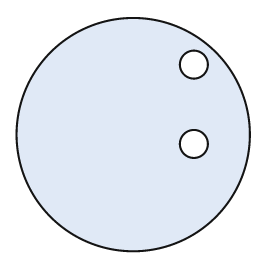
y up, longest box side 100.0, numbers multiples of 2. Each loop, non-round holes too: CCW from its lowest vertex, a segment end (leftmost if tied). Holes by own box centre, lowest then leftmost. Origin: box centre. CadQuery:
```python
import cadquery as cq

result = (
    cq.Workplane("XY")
    .moveTo(0.0, 0.0)
    .circle(50.0)
    .moveTo(26.0, -4.0)
    .circle(6.0)
    .moveTo(26.0, 30.0)
    .circle(6.0)
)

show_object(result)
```